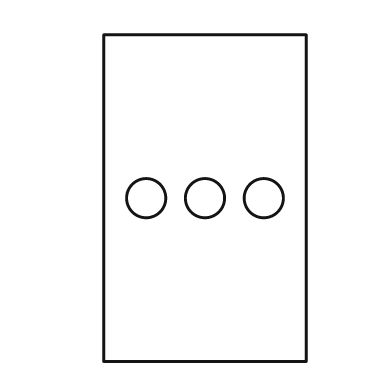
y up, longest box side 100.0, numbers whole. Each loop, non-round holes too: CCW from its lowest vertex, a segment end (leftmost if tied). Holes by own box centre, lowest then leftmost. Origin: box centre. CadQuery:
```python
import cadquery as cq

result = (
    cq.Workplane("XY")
    .moveTo(-31.0, -50.0)
    .lineTo(31.0, -50.0)
    .lineTo(31.0, 50.0)
    .lineTo(-31.0, 50.0)
    .close()
    .moveTo(-18.0, 0.0)
    .circle(6.0)
    .moveTo(0.0, 0.0)
    .circle(6.0)
    .moveTo(18.0, 0.0)
    .circle(6.0)
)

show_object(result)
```